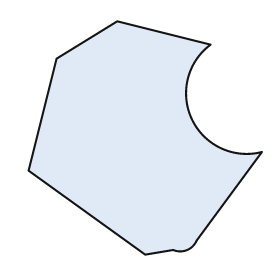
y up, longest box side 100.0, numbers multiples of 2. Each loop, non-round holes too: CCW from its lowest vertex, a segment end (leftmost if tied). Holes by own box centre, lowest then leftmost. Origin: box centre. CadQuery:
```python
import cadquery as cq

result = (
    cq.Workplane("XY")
    .moveTo(0.0, -50.0)
    .lineTo(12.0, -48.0)
    .threePointArc((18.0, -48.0), (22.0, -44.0))
    .lineTo(50.0, -6.0)
    .threePointArc((20.0, 8.0), (28.0, 40.0))
    .lineTo(-12.0, 50.0)
    .lineTo(-38.0, 34.0)
    .lineTo(-50.0, -14.0)
    .close()
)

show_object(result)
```